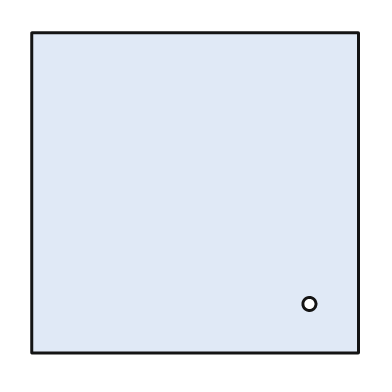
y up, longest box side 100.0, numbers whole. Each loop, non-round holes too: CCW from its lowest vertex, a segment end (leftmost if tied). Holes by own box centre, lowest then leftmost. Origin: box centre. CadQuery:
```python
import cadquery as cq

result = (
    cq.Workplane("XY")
    .moveTo(-50.0, -49.0)
    .lineTo(50.0, -49.0)
    .lineTo(50.0, 49.0)
    .lineTo(-50.0, 49.0)
    .close()
    .moveTo(35.0, -34.0)
    .circle(2.0)
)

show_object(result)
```